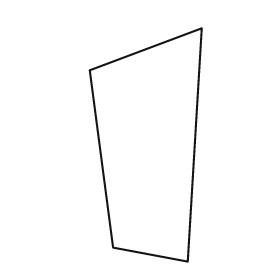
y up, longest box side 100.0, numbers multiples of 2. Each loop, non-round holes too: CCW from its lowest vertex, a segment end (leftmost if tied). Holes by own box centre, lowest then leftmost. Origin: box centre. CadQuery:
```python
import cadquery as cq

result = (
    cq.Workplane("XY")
    .moveTo(18.0, -50.0)
    .lineTo(24.0, 50.0)
    .lineTo(-24.0, 32.0)
    .lineTo(-14.0, -44.0)
    .close()
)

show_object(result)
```